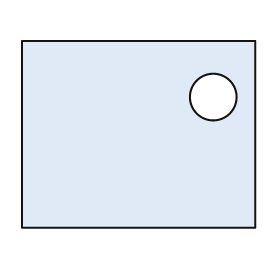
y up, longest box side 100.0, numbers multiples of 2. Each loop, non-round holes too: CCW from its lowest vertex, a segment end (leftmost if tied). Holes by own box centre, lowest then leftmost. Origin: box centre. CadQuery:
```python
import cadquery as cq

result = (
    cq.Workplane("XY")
    .moveTo(-50.0, -40.0)
    .lineTo(50.0, -40.0)
    .lineTo(50.0, 40.0)
    .lineTo(-50.0, 40.0)
    .close()
    .moveTo(32.0, 16.0)
    .circle(10.0)
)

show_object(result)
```